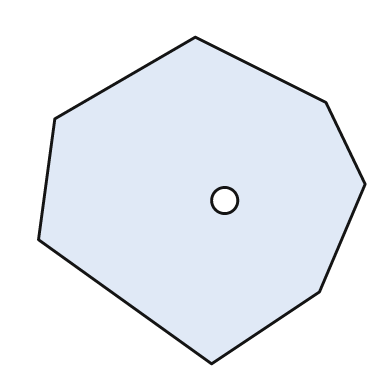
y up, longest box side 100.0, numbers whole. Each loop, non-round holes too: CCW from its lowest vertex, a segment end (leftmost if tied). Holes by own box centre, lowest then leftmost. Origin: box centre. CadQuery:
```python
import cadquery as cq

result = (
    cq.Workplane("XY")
    .moveTo(3.0, -50.0)
    .lineTo(36.0, -28.0)
    .lineTo(50.0, 5.0)
    .lineTo(38.0, 30.0)
    .lineTo(-2.0, 50.0)
    .lineTo(-45.0, 25.0)
    .lineTo(-50.0, -12.0)
    .close()
    .moveTo(7.0, 0.0)
    .circle(4.0)
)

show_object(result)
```